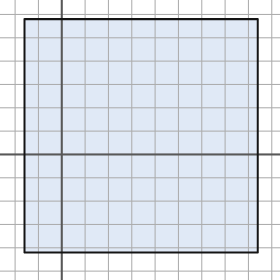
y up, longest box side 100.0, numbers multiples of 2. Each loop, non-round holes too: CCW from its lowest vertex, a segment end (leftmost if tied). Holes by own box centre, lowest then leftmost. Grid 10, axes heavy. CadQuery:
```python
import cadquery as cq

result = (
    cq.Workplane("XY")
    .moveTo(-16.0, -42.0)
    .lineTo(84.0, -42.0)
    .lineTo(84.0, 58.0)
    .lineTo(-16.0, 58.0)
    .close()
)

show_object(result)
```